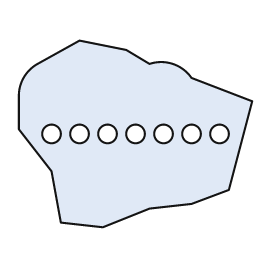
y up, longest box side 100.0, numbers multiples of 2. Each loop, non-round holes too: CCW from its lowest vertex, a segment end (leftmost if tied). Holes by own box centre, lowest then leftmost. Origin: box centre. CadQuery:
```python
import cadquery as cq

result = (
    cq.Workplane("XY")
    .moveTo(-14.0, -40.0)
    .lineTo(6.0, -32.0)
    .lineTo(24.0, -30.0)
    .lineTo(40.0, -24.0)
    .lineTo(50.0, 14.0)
    .lineTo(24.0, 24.0)
    .threePointArc((16.0, 30.0), (6.0, 30.0))
    .lineTo(-4.0, 36.0)
    .lineTo(-24.0, 40.0)
    .lineTo(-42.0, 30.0)
    .threePointArc((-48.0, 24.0), (-50.0, 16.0))
    .lineTo(-50.0, 2.0)
    .lineTo(-36.0, -16.0)
    .lineTo(-32.0, -38.0)
    .close()
    .moveTo(-36.0, 0.0)
    .circle(4.0)
    .moveTo(-24.0, 0.0)
    .circle(4.0)
    .moveTo(-12.0, 0.0)
    .circle(4.0)
    .moveTo(0.0, 0.0)
    .circle(4.0)
    .moveTo(12.0, 0.0)
    .circle(4.0)
    .moveTo(24.0, 0.0)
    .circle(4.0)
    .moveTo(36.0, 0.0)
    .circle(4.0)
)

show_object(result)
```